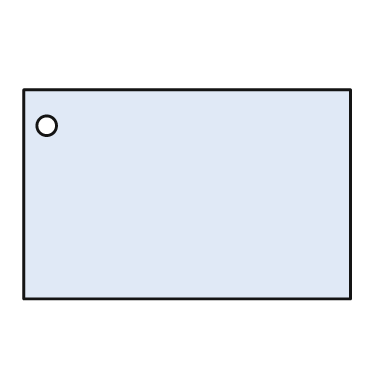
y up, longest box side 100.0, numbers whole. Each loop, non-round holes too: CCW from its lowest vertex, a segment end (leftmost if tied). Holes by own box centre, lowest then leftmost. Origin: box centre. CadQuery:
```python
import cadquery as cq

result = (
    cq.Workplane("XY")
    .moveTo(-50.0, -32.0)
    .lineTo(50.0, -32.0)
    .lineTo(50.0, 32.0)
    .lineTo(-50.0, 32.0)
    .close()
    .moveTo(-43.0, 21.0)
    .circle(3.0)
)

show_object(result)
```